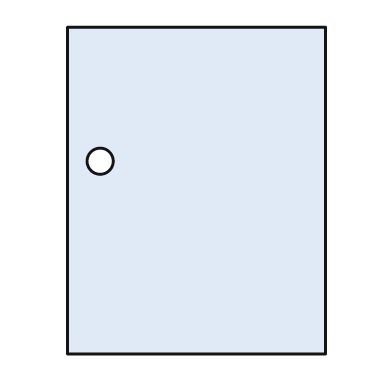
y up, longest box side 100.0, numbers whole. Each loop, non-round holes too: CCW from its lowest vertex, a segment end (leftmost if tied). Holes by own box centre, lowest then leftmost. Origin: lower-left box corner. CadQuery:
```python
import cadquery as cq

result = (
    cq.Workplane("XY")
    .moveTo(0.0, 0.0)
    .lineTo(79.0, 0.0)
    .lineTo(79.0, 100.0)
    .lineTo(0.0, 100.0)
    .close()
    .moveTo(10.0, 59.0)
    .circle(4.0)
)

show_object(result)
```